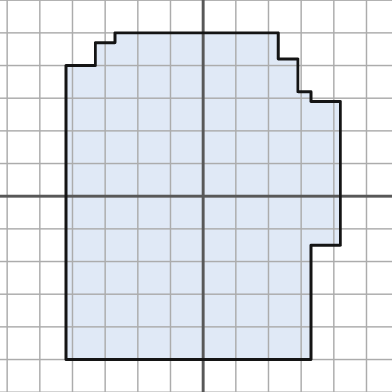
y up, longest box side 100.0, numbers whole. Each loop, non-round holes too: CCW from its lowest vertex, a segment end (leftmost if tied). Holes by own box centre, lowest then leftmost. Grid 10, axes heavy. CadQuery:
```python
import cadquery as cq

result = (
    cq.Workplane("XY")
    .moveTo(-42.0, -50.0)
    .lineTo(33.0, -50.0)
    .lineTo(33.0, -15.0)
    .lineTo(42.0, -15.0)
    .lineTo(42.0, 29.0)
    .lineTo(33.0, 29.0)
    .lineTo(33.0, 32.0)
    .lineTo(29.0, 32.0)
    .lineTo(29.0, 42.0)
    .lineTo(23.0, 42.0)
    .lineTo(23.0, 50.0)
    .lineTo(-27.0, 50.0)
    .lineTo(-27.0, 47.0)
    .lineTo(-33.0, 47.0)
    .lineTo(-33.0, 40.0)
    .lineTo(-42.0, 40.0)
    .close()
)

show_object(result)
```